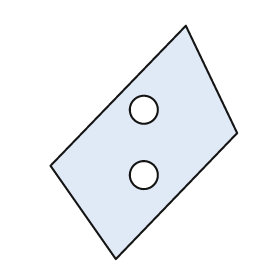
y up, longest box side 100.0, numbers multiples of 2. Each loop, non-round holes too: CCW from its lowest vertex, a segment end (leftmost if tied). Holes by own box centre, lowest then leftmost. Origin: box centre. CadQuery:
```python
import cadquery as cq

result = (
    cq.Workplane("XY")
    .moveTo(-12.0, -50.0)
    .lineTo(40.0, 4.0)
    .lineTo(18.0, 50.0)
    .lineTo(-40.0, -10.0)
    .close()
    .moveTo(0.0, -14.0)
    .circle(6.0)
    .moveTo(0.0, 14.0)
    .circle(6.0)
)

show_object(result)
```